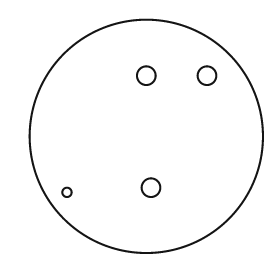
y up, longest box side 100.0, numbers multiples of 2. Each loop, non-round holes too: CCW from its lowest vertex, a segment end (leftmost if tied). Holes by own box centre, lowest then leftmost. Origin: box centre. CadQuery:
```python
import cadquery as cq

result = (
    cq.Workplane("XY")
    .moveTo(0.0, 0.0)
    .circle(50.0)
    .moveTo(-34.0, -24.0)
    .circle(2.0)
    .moveTo(2.0, -22.0)
    .circle(4.0)
    .moveTo(0.0, 26.0)
    .circle(4.0)
    .moveTo(26.0, 26.0)
    .circle(4.0)
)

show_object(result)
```